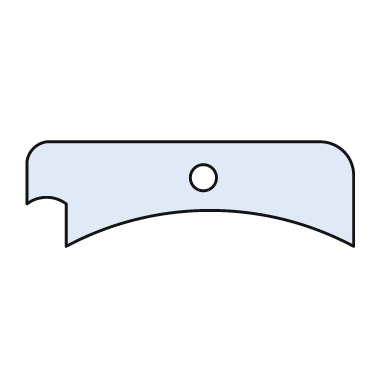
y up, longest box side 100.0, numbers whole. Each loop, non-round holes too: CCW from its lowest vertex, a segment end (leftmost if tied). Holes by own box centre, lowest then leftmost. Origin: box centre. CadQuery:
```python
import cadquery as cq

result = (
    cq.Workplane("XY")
    .moveTo(-38.0, -16.0)
    .threePointArc((6.0, -5.0), (50.0, -16.0))
    .lineTo(50.0, 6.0)
    .threePointArc((47.0, 13.0), (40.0, 16.0))
    .lineTo(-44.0, 16.0)
    .threePointArc((-48.0, 14.0), (-50.0, 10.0))
    .lineTo(-50.0, -3.0)
    .threePointArc((-44.0, -1.0), (-38.0, -3.0))
    .close()
    .moveTo(4.0, 5.0)
    .circle(4.0)
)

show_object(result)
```